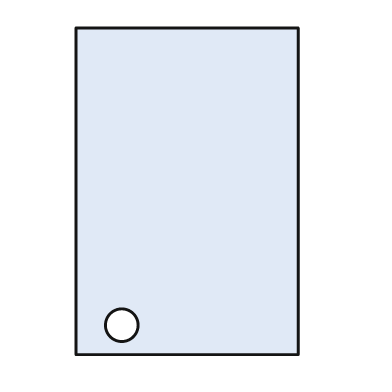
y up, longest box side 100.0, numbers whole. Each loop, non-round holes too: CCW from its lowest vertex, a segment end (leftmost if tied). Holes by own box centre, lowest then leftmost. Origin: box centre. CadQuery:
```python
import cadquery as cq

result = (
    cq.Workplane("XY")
    .moveTo(-34.0, -50.0)
    .lineTo(34.0, -50.0)
    .lineTo(34.0, 50.0)
    .lineTo(-34.0, 50.0)
    .close()
    .moveTo(-20.0, -41.0)
    .circle(5.0)
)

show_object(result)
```